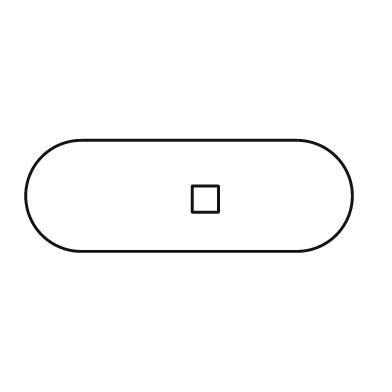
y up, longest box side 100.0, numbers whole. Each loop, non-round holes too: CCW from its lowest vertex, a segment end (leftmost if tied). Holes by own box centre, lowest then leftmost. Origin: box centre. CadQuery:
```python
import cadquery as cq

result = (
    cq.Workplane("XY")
    .moveTo(-33.0, -17.0)
    .lineTo(33.0, -17.0)
    .threePointArc((50.0, 0.0), (33.0, 17.0))
    .lineTo(-33.0, 17.0)
    .threePointArc((-50.0, 0.0), (-33.0, -17.0))
    .close()
    .moveTo(1.0, -5.0)
    .lineTo(9.0, -5.0)
    .lineTo(9.0, 3.0)
    .lineTo(1.0, 3.0)
    .close()
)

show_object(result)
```